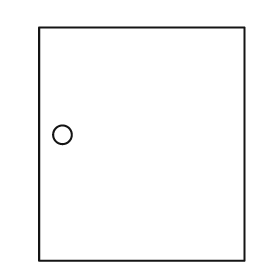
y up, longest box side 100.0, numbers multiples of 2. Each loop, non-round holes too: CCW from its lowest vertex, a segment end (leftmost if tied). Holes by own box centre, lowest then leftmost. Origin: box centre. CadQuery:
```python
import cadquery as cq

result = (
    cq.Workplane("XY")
    .moveTo(-44.0, -50.0)
    .lineTo(44.0, -50.0)
    .lineTo(44.0, 50.0)
    .lineTo(-44.0, 50.0)
    .close()
    .moveTo(-34.0, 4.0)
    .circle(4.0)
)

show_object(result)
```